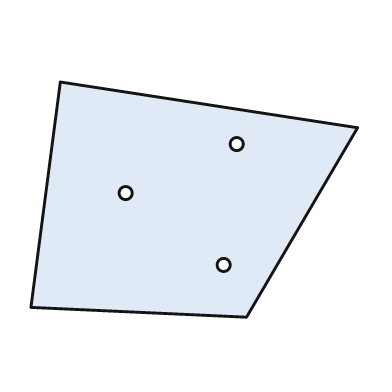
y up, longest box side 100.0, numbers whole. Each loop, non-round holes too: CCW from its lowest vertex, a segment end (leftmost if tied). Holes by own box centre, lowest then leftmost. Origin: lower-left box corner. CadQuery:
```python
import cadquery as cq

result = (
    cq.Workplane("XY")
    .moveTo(66.0, 0.0)
    .lineTo(100.0, 58.0)
    .lineTo(9.0, 72.0)
    .lineTo(0.0, 3.0)
    .close()
    .moveTo(59.0, 16.0)
    .circle(2.0)
    .moveTo(29.0, 38.0)
    .circle(2.0)
    .moveTo(63.0, 53.0)
    .circle(2.0)
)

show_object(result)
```